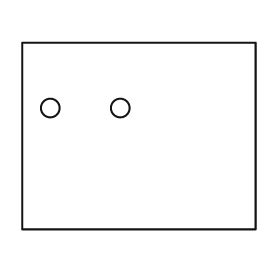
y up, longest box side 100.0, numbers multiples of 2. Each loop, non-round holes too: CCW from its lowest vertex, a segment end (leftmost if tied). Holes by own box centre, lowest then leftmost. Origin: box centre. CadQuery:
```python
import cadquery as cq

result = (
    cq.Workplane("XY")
    .moveTo(-50.0, -40.0)
    .lineTo(50.0, -40.0)
    .lineTo(50.0, 40.0)
    .lineTo(-50.0, 40.0)
    .close()
    .moveTo(-38.0, 12.0)
    .circle(4.0)
    .moveTo(-8.0, 12.0)
    .circle(4.0)
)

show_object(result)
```